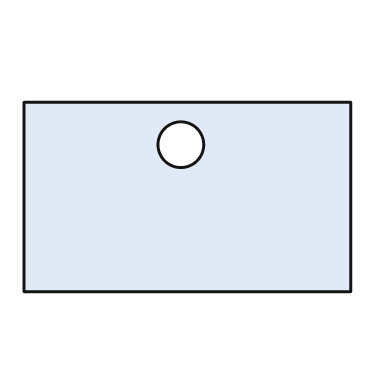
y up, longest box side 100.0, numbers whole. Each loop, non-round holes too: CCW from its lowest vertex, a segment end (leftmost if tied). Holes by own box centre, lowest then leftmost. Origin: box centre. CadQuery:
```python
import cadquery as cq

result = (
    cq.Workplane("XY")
    .moveTo(-50.0, -29.0)
    .lineTo(50.0, -29.0)
    .lineTo(50.0, 29.0)
    .lineTo(-50.0, 29.0)
    .close()
    .moveTo(-2.0, 16.0)
    .circle(7.0)
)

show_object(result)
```